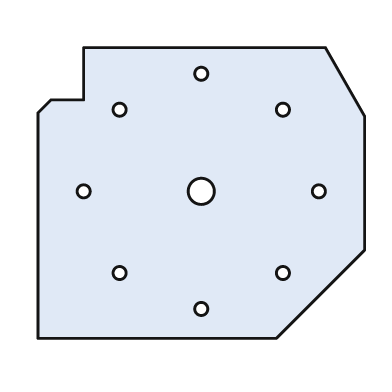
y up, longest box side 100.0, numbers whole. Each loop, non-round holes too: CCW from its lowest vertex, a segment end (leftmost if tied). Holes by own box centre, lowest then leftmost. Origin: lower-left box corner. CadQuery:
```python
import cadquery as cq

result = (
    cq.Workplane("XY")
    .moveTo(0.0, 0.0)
    .lineTo(73.0, 0.0)
    .lineTo(100.0, 27.0)
    .lineTo(100.0, 68.0)
    .lineTo(88.0, 89.0)
    .lineTo(14.0, 89.0)
    .lineTo(14.0, 73.0)
    .lineTo(4.0, 73.0)
    .lineTo(0.0, 69.0)
    .close()
    .moveTo(50.0, 9.0)
    .circle(2.0)
    .moveTo(25.0, 20.0)
    .circle(2.0)
    .moveTo(75.0, 20.0)
    .circle(2.0)
    .moveTo(14.0, 45.0)
    .circle(2.0)
    .moveTo(50.0, 45.0)
    .circle(4.0)
    .moveTo(86.0, 45.0)
    .circle(2.0)
    .moveTo(25.0, 70.0)
    .circle(2.0)
    .moveTo(75.0, 70.0)
    .circle(2.0)
    .moveTo(50.0, 81.0)
    .circle(2.0)
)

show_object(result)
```